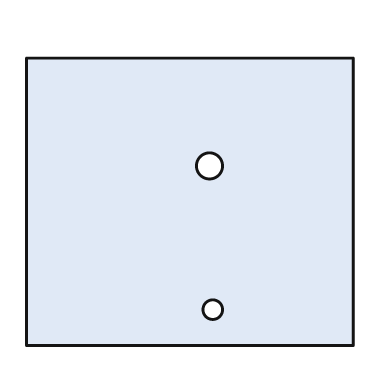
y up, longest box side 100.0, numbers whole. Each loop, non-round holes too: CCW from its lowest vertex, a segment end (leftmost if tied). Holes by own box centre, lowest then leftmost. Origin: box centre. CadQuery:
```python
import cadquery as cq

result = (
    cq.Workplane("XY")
    .moveTo(-50.0, -44.0)
    .lineTo(50.0, -44.0)
    .lineTo(50.0, 44.0)
    .lineTo(-50.0, 44.0)
    .close()
    .moveTo(7.0, -33.0)
    .circle(3.0)
    .moveTo(6.0, 11.0)
    .circle(4.0)
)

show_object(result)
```